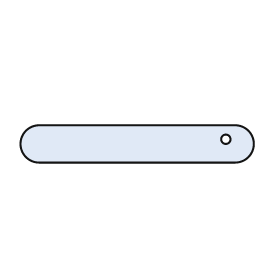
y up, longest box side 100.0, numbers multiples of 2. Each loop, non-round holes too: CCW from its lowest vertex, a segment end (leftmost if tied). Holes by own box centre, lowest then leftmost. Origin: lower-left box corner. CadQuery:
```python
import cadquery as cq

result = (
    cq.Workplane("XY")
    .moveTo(8.0, 0.0)
    .lineTo(92.0, 0.0)
    .threePointArc((100.0, 8.0), (92.0, 16.0))
    .lineTo(8.0, 16.0)
    .threePointArc((0.0, 8.0), (8.0, 0.0))
    .close()
    .moveTo(88.0, 10.0)
    .circle(2.0)
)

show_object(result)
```